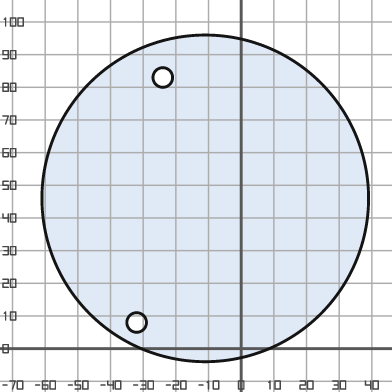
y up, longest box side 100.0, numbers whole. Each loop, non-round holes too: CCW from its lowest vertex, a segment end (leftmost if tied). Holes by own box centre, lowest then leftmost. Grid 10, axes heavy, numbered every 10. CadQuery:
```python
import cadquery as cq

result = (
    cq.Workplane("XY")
    .moveTo(-11.0, 46.0)
    .circle(50.0)
    .moveTo(-32.0, 8.0)
    .circle(3.0)
    .moveTo(-24.0, 83.0)
    .circle(3.0)
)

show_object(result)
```